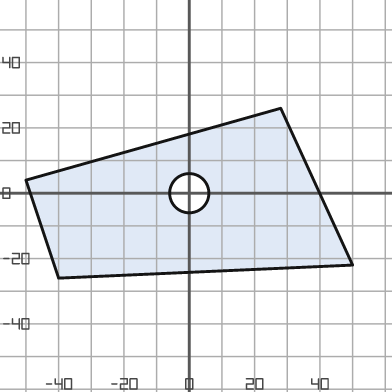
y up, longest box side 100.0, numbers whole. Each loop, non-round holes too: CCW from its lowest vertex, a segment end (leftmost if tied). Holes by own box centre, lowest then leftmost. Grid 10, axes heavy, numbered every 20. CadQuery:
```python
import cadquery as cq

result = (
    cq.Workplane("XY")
    .moveTo(-40.0, -26.0)
    .lineTo(50.0, -22.0)
    .lineTo(28.0, 26.0)
    .lineTo(-50.0, 4.0)
    .close()
    .moveTo(0.0, 0.0)
    .circle(6.0)
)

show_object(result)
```